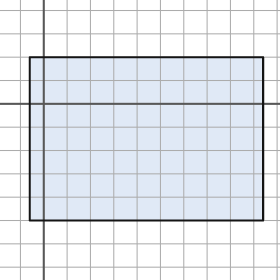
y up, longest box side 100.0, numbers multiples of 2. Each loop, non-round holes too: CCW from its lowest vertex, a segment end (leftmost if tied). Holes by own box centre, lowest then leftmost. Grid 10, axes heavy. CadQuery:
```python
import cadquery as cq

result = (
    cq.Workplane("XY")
    .moveTo(-6.0, -50.0)
    .lineTo(94.0, -50.0)
    .lineTo(94.0, 20.0)
    .lineTo(-6.0, 20.0)
    .close()
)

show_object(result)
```